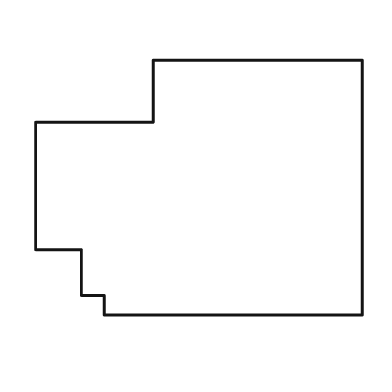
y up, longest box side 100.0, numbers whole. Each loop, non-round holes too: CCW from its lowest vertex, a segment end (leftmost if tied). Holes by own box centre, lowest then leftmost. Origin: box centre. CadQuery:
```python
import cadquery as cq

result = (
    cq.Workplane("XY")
    .moveTo(-29.0, -39.0)
    .lineTo(50.0, -39.0)
    .lineTo(50.0, 39.0)
    .lineTo(-14.0, 39.0)
    .lineTo(-14.0, 20.0)
    .lineTo(-50.0, 20.0)
    .lineTo(-50.0, -19.0)
    .lineTo(-36.0, -19.0)
    .lineTo(-36.0, -33.0)
    .lineTo(-29.0, -33.0)
    .close()
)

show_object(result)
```